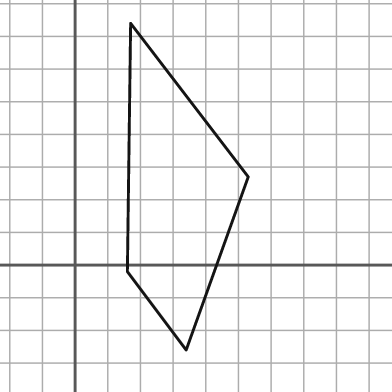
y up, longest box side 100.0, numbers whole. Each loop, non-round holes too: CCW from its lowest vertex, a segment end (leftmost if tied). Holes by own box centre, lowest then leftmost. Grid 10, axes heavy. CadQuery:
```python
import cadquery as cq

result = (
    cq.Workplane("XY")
    .moveTo(34.0, -26.0)
    .lineTo(53.0, 27.0)
    .lineTo(17.0, 74.0)
    .lineTo(16.0, -2.0)
    .close()
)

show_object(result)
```